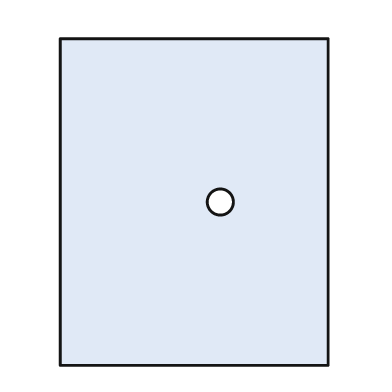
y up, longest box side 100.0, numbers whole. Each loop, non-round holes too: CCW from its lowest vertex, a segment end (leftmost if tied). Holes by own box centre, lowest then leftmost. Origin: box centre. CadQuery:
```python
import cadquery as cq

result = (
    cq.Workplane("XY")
    .moveTo(-41.0, -50.0)
    .lineTo(41.0, -50.0)
    .lineTo(41.0, 50.0)
    .lineTo(-41.0, 50.0)
    .close()
    .moveTo(8.0, 0.0)
    .circle(4.0)
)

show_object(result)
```